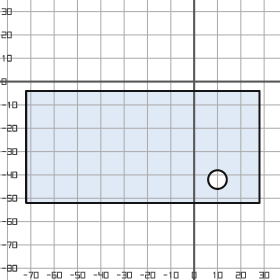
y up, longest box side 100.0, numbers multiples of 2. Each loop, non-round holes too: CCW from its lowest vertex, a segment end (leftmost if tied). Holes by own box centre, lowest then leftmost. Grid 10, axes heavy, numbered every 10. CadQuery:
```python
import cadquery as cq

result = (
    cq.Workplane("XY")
    .moveTo(-72.0, -52.0)
    .lineTo(28.0, -52.0)
    .lineTo(28.0, -4.0)
    .lineTo(-72.0, -4.0)
    .close()
    .moveTo(10.0, -42.0)
    .circle(4.0)
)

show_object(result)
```